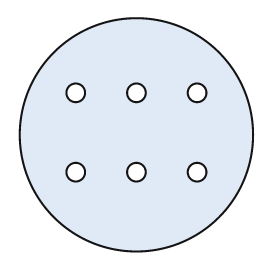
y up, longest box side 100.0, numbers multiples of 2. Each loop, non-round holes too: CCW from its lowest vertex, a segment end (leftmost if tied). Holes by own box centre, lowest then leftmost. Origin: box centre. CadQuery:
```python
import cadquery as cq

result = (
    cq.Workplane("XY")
    .moveTo(0.0, 0.0)
    .circle(50.0)
    .moveTo(-26.0, -16.0)
    .circle(4.0)
    .moveTo(0.0, -16.0)
    .circle(4.0)
    .moveTo(26.0, -16.0)
    .circle(4.0)
    .moveTo(-26.0, 18.0)
    .circle(4.0)
    .moveTo(0.0, 18.0)
    .circle(4.0)
    .moveTo(26.0, 18.0)
    .circle(4.0)
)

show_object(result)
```